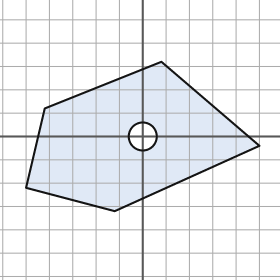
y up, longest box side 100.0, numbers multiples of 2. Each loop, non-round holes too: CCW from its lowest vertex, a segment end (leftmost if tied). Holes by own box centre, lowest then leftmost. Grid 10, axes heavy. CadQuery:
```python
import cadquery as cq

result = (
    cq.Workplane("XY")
    .moveTo(-12.0, -32.0)
    .lineTo(50.0, -4.0)
    .lineTo(8.0, 32.0)
    .lineTo(-42.0, 12.0)
    .lineTo(-50.0, -22.0)
    .close()
    .moveTo(0.0, 0.0)
    .circle(6.0)
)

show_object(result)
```